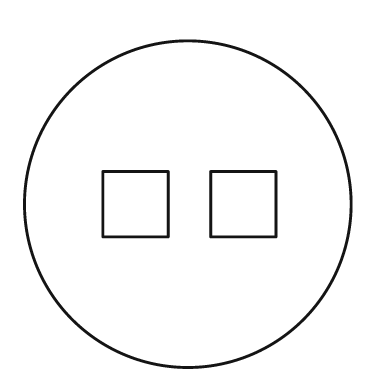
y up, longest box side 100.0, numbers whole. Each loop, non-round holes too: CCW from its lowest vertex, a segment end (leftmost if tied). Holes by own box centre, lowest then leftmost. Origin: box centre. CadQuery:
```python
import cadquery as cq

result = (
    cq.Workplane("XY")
    .moveTo(0.0, 0.0)
    .circle(50.0)
    .moveTo(-26.0, -10.0)
    .lineTo(-6.0, -10.0)
    .lineTo(-6.0, 10.0)
    .lineTo(-26.0, 10.0)
    .close()
    .moveTo(7.0, -10.0)
    .lineTo(27.0, -10.0)
    .lineTo(27.0, 10.0)
    .lineTo(7.0, 10.0)
    .close()
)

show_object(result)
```